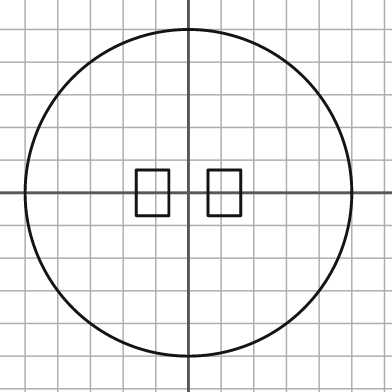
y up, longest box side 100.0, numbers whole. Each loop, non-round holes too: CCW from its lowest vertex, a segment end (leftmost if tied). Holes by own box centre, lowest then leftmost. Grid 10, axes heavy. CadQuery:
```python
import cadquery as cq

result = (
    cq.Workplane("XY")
    .moveTo(0.0, 0.0)
    .circle(50.0)
    .moveTo(-16.0, -7.0)
    .lineTo(-6.0, -7.0)
    .lineTo(-6.0, 7.0)
    .lineTo(-16.0, 7.0)
    .close()
    .moveTo(6.0, -7.0)
    .lineTo(16.0, -7.0)
    .lineTo(16.0, 7.0)
    .lineTo(6.0, 7.0)
    .close()
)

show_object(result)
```